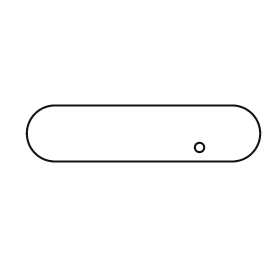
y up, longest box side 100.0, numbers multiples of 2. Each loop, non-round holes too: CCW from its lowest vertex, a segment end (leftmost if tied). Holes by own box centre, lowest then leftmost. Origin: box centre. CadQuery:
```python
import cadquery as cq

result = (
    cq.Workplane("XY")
    .moveTo(-38.0, -12.0)
    .lineTo(38.0, -12.0)
    .threePointArc((50.0, 0.0), (38.0, 12.0))
    .lineTo(-38.0, 12.0)
    .threePointArc((-50.0, 0.0), (-38.0, -12.0))
    .close()
    .moveTo(24.0, -6.0)
    .circle(2.0)
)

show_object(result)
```